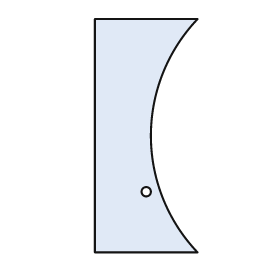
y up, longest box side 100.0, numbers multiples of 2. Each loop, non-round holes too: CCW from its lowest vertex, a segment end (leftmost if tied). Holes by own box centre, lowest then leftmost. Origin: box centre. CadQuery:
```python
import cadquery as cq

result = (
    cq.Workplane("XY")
    .moveTo(-22.0, -50.0)
    .lineTo(22.0, -50.0)
    .threePointArc((2.0, 0.0), (22.0, 50.0))
    .lineTo(-22.0, 50.0)
    .close()
    .moveTo(0.0, -24.0)
    .circle(2.0)
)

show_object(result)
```